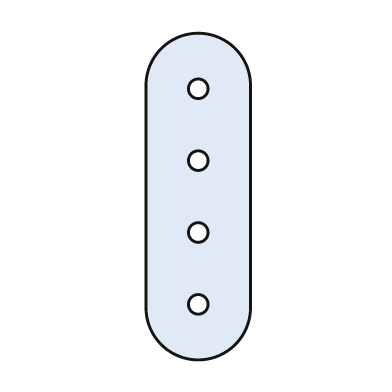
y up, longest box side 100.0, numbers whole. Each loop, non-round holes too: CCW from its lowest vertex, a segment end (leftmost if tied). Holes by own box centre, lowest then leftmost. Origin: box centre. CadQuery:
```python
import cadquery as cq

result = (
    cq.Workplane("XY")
    .moveTo(-16.0, -34.0)
    .threePointArc((0.0, -50.0), (16.0, -34.0))
    .lineTo(16.0, 34.0)
    .threePointArc((0.0, 50.0), (-16.0, 34.0))
    .close()
    .moveTo(0.0, -33.0)
    .circle(3.0)
    .moveTo(0.0, -11.0)
    .circle(3.0)
    .moveTo(0.0, 11.0)
    .circle(3.0)
    .moveTo(0.0, 33.0)
    .circle(3.0)
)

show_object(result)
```